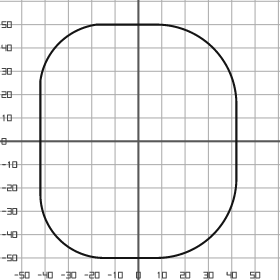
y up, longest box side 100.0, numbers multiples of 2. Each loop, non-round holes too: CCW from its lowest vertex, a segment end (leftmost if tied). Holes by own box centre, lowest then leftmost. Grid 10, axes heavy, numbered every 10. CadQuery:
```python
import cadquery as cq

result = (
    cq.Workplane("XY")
    .moveTo(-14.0, -50.0)
    .lineTo(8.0, -50.0)
    .threePointArc((32.0, -40.0), (42.0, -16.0))
    .lineTo(42.0, 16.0)
    .threePointArc((32.0, 40.0), (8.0, 50.0))
    .lineTo(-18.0, 50.0)
    .threePointArc((-34.0, 42.0), (-42.0, 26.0))
    .lineTo(-42.0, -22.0)
    .threePointArc((-34.0, -42.0), (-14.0, -50.0))
    .close()
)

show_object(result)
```